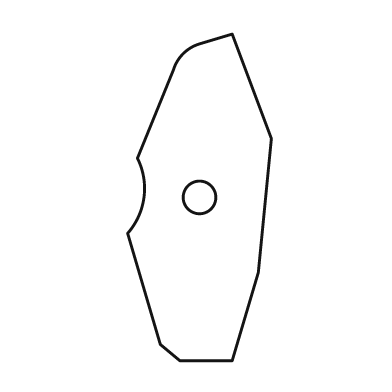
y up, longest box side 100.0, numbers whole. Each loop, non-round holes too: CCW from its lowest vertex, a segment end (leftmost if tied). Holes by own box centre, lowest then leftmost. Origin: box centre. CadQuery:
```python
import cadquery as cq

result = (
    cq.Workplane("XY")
    .moveTo(-6.0, -50.0)
    .lineTo(10.0, -50.0)
    .lineTo(18.0, -23.0)
    .lineTo(22.0, 18.0)
    .lineTo(10.0, 50.0)
    .lineTo(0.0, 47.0)
    .threePointArc((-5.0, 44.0), (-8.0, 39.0))
    .lineTo(-19.0, 12.0)
    .threePointArc((-17.0, 0.0), (-22.0, -11.0))
    .lineTo(-12.0, -45.0)
    .close()
    .moveTo(0.0, 0.0)
    .circle(5.0)
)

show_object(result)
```